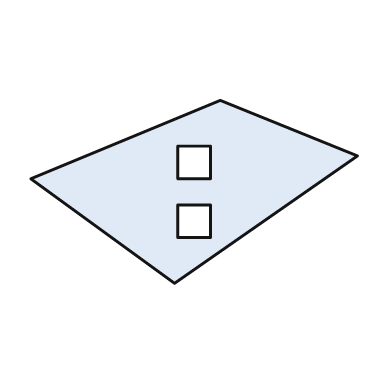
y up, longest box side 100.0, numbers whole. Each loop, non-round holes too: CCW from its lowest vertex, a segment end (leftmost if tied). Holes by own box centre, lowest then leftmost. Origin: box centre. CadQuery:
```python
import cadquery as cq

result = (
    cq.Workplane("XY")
    .moveTo(-6.0, -28.0)
    .lineTo(50.0, 11.0)
    .lineTo(8.0, 28.0)
    .lineTo(-50.0, 4.0)
    .close()
    .moveTo(-5.0, -14.0)
    .lineTo(5.0, -14.0)
    .lineTo(5.0, -4.0)
    .lineTo(-5.0, -4.0)
    .close()
    .moveTo(-5.0, 4.0)
    .lineTo(5.0, 4.0)
    .lineTo(5.0, 14.0)
    .lineTo(-5.0, 14.0)
    .close()
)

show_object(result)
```